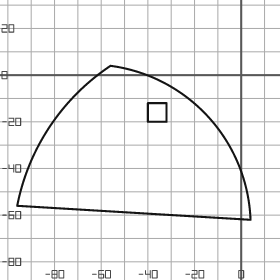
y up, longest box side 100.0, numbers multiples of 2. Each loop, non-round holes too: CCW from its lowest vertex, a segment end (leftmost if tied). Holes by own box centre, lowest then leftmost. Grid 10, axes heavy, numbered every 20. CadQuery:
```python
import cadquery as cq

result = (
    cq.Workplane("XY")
    .moveTo(4.0, -62.0)
    .threePointArc((-14.0, -18.0), (-56.0, 4.0))
    .threePointArc((-82.0, -22.0), (-96.0, -56.0))
    .close()
    .moveTo(-40.0, -20.0)
    .lineTo(-32.0, -20.0)
    .lineTo(-32.0, -12.0)
    .lineTo(-40.0, -12.0)
    .close()
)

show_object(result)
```